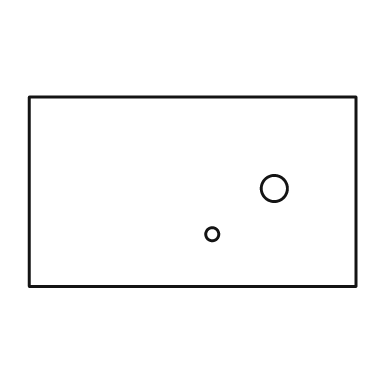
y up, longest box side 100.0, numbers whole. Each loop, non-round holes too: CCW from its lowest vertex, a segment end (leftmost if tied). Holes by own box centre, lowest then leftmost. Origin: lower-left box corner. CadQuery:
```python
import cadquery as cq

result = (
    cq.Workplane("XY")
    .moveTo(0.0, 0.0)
    .lineTo(100.0, 0.0)
    .lineTo(100.0, 58.0)
    .lineTo(0.0, 58.0)
    .close()
    .moveTo(56.0, 16.0)
    .circle(2.0)
    .moveTo(75.0, 30.0)
    .circle(4.0)
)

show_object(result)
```